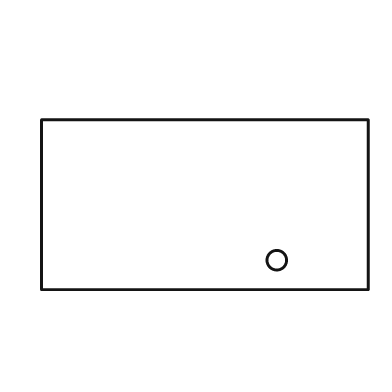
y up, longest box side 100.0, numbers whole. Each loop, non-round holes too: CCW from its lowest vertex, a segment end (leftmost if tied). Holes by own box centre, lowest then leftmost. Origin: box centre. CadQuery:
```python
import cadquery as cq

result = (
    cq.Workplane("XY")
    .moveTo(-50.0, -26.0)
    .lineTo(50.0, -26.0)
    .lineTo(50.0, 26.0)
    .lineTo(-50.0, 26.0)
    .close()
    .moveTo(22.0, -17.0)
    .circle(3.0)
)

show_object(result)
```